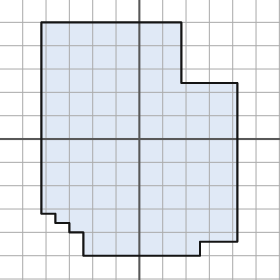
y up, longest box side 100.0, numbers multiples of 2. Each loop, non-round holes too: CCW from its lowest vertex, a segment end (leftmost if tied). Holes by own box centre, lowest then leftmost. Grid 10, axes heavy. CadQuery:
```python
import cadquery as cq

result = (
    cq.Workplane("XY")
    .moveTo(-24.0, -50.0)
    .lineTo(26.0, -50.0)
    .lineTo(26.0, -44.0)
    .lineTo(42.0, -44.0)
    .lineTo(42.0, 24.0)
    .lineTo(18.0, 24.0)
    .lineTo(18.0, 50.0)
    .lineTo(-42.0, 50.0)
    .lineTo(-42.0, -32.0)
    .lineTo(-36.0, -32.0)
    .lineTo(-36.0, -36.0)
    .lineTo(-30.0, -36.0)
    .lineTo(-30.0, -40.0)
    .lineTo(-24.0, -40.0)
    .close()
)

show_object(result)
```